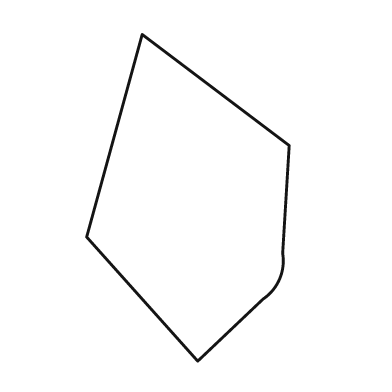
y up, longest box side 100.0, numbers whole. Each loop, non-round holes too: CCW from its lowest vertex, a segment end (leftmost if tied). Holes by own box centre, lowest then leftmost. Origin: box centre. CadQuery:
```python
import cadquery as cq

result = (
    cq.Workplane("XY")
    .moveTo(3.0, -50.0)
    .lineTo(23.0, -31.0)
    .threePointArc((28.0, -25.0), (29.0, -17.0))
    .lineTo(31.0, 16.0)
    .lineTo(-14.0, 50.0)
    .lineTo(-31.0, -12.0)
    .close()
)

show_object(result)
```